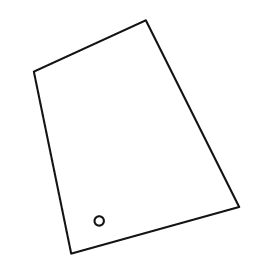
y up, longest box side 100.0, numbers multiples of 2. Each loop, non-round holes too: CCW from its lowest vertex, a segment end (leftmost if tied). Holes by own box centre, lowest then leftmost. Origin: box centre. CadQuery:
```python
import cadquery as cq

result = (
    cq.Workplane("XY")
    .moveTo(-28.0, -50.0)
    .lineTo(44.0, -30.0)
    .lineTo(4.0, 50.0)
    .lineTo(-44.0, 28.0)
    .close()
    .moveTo(-16.0, -36.0)
    .circle(2.0)
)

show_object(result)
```